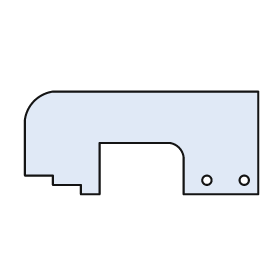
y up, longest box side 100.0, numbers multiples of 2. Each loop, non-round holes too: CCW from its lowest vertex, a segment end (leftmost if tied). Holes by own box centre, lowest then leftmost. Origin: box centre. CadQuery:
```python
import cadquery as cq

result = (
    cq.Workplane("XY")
    .moveTo(-26.0, -22.0)
    .lineTo(-18.0, -22.0)
    .lineTo(-18.0, 0.0)
    .lineTo(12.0, 0.0)
    .threePointArc((16.0, -2.0), (18.0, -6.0))
    .lineTo(18.0, -22.0)
    .lineTo(50.0, -22.0)
    .lineTo(50.0, 22.0)
    .lineTo(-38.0, 22.0)
    .threePointArc((-46.0, 18.0), (-50.0, 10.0))
    .lineTo(-50.0, -14.0)
    .lineTo(-38.0, -14.0)
    .lineTo(-38.0, -18.0)
    .lineTo(-26.0, -18.0)
    .close()
    .moveTo(28.0, -16.0)
    .circle(2.0)
    .moveTo(44.0, -16.0)
    .circle(2.0)
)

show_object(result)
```